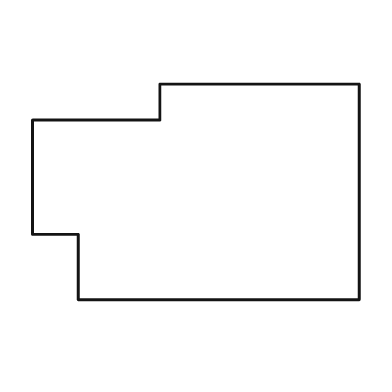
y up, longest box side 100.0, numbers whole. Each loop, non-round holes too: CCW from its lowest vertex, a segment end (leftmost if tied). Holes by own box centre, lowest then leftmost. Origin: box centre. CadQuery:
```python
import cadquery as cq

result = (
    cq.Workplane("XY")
    .moveTo(-36.0, -33.0)
    .lineTo(50.0, -33.0)
    .lineTo(50.0, 33.0)
    .lineTo(-11.0, 33.0)
    .lineTo(-11.0, 22.0)
    .lineTo(-50.0, 22.0)
    .lineTo(-50.0, -13.0)
    .lineTo(-36.0, -13.0)
    .close()
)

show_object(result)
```